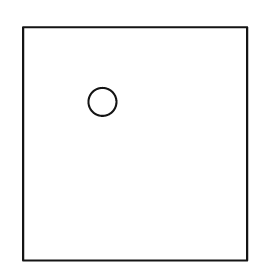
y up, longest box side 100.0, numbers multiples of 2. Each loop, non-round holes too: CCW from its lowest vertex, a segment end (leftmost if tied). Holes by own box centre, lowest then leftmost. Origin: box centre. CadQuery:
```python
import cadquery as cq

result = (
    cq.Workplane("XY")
    .moveTo(-48.0, -50.0)
    .lineTo(48.0, -50.0)
    .lineTo(48.0, 50.0)
    .lineTo(-48.0, 50.0)
    .close()
    .moveTo(-14.0, 18.0)
    .circle(6.0)
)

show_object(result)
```